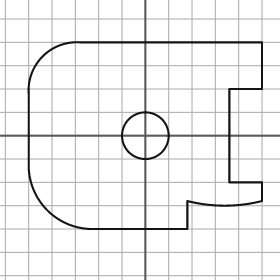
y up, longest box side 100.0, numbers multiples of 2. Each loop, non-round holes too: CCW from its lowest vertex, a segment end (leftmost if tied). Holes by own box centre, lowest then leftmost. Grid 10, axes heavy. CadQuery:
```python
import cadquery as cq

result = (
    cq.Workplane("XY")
    .moveTo(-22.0, -40.0)
    .lineTo(18.0, -40.0)
    .lineTo(18.0, -28.0)
    .threePointArc((34.0, -30.0), (50.0, -28.0))
    .lineTo(50.0, -20.0)
    .lineTo(36.0, -20.0)
    .lineTo(36.0, 20.0)
    .lineTo(50.0, 20.0)
    .lineTo(50.0, 40.0)
    .lineTo(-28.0, 40.0)
    .threePointArc((-44.0, 34.0), (-50.0, 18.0))
    .lineTo(-50.0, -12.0)
    .threePointArc((-42.0, -32.0), (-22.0, -40.0))
    .close()
    .moveTo(0.0, 0.0)
    .circle(10.0)
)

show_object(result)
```